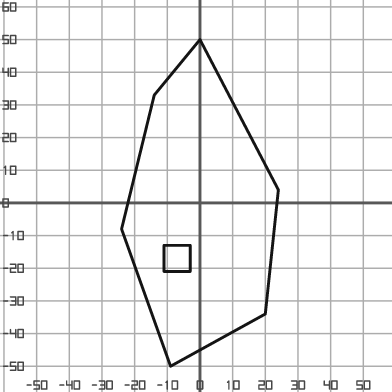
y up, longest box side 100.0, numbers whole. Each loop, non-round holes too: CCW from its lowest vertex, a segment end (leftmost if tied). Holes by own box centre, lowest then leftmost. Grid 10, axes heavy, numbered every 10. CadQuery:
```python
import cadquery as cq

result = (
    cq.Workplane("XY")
    .moveTo(-9.0, -50.0)
    .lineTo(20.0, -34.0)
    .lineTo(24.0, 4.0)
    .lineTo(0.0, 50.0)
    .lineTo(-14.0, 33.0)
    .lineTo(-24.0, -8.0)
    .close()
    .moveTo(-11.0, -21.0)
    .lineTo(-3.0, -21.0)
    .lineTo(-3.0, -13.0)
    .lineTo(-11.0, -13.0)
    .close()
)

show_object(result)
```